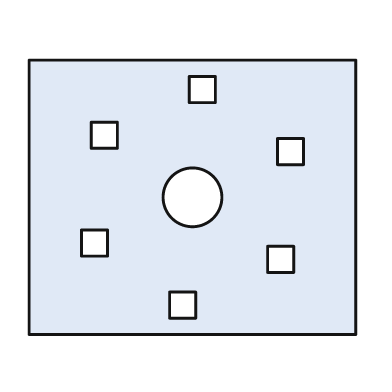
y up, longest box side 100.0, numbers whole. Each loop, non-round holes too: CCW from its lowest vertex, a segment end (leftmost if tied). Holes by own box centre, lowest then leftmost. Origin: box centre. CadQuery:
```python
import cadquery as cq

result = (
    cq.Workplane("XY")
    .moveTo(-50.0, -42.0)
    .lineTo(50.0, -42.0)
    .lineTo(50.0, 42.0)
    .lineTo(-50.0, 42.0)
    .close()
    .moveTo(-7.0, -37.0)
    .lineTo(1.0, -37.0)
    .lineTo(1.0, -29.0)
    .lineTo(-7.0, -29.0)
    .close()
    .moveTo(23.0, -23.0)
    .lineTo(31.0, -23.0)
    .lineTo(31.0, -15.0)
    .lineTo(23.0, -15.0)
    .close()
    .moveTo(-34.0, -18.0)
    .lineTo(-26.0, -18.0)
    .lineTo(-26.0, -10.0)
    .lineTo(-34.0, -10.0)
    .close()
    .moveTo(0.0, 0.0)
    .circle(9.0)
    .moveTo(26.0, 10.0)
    .lineTo(34.0, 10.0)
    .lineTo(34.0, 18.0)
    .lineTo(26.0, 18.0)
    .close()
    .moveTo(-31.0, 15.0)
    .lineTo(-23.0, 15.0)
    .lineTo(-23.0, 23.0)
    .lineTo(-31.0, 23.0)
    .close()
    .moveTo(-1.0, 29.0)
    .lineTo(7.0, 29.0)
    .lineTo(7.0, 37.0)
    .lineTo(-1.0, 37.0)
    .close()
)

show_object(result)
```